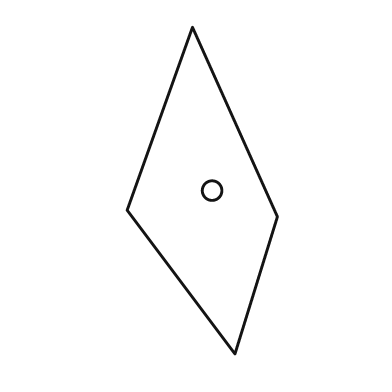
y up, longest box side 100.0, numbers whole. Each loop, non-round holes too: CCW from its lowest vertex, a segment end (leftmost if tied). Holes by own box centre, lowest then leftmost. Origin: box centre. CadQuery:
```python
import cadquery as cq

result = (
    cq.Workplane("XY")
    .moveTo(10.0, -50.0)
    .lineTo(23.0, -8.0)
    .lineTo(-3.0, 50.0)
    .lineTo(-23.0, -6.0)
    .close()
    .moveTo(3.0, 0.0)
    .circle(3.0)
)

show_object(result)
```